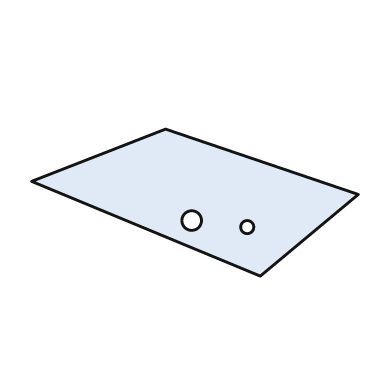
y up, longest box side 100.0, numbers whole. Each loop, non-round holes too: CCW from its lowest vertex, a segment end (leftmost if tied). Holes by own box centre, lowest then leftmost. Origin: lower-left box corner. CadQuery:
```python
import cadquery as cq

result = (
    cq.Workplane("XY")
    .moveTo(70.0, 0.0)
    .lineTo(100.0, 25.0)
    .lineTo(41.0, 45.0)
    .lineTo(0.0, 29.0)
    .close()
    .moveTo(66.0, 15.0)
    .circle(2.0)
    .moveTo(49.0, 17.0)
    .circle(3.0)
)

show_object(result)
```